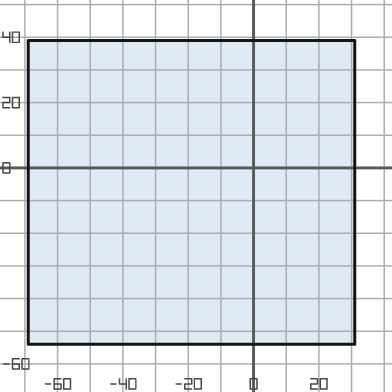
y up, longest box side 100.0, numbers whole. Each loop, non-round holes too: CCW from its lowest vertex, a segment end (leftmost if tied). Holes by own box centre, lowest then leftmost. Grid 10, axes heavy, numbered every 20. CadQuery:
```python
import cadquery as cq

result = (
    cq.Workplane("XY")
    .moveTo(-69.0, -54.0)
    .lineTo(31.0, -54.0)
    .lineTo(31.0, 39.0)
    .lineTo(-69.0, 39.0)
    .close()
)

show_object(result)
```